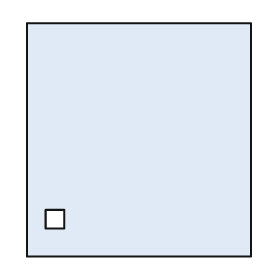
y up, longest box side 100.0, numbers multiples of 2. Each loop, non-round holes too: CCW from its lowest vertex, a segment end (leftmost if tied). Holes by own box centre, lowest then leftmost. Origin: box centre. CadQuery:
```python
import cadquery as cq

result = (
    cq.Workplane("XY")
    .moveTo(-48.0, -50.0)
    .lineTo(48.0, -50.0)
    .lineTo(48.0, 50.0)
    .lineTo(-48.0, 50.0)
    .close()
    .moveTo(-40.0, -38.0)
    .lineTo(-32.0, -38.0)
    .lineTo(-32.0, -30.0)
    .lineTo(-40.0, -30.0)
    .close()
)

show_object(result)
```